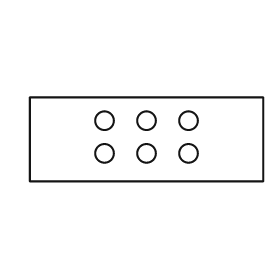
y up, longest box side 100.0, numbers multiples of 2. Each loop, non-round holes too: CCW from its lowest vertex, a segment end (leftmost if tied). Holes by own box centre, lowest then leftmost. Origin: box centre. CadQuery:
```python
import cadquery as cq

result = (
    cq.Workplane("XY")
    .moveTo(-50.0, -18.0)
    .lineTo(50.0, -18.0)
    .lineTo(50.0, 18.0)
    .lineTo(-50.0, 18.0)
    .close()
    .moveTo(-18.0, -6.0)
    .circle(4.0)
    .moveTo(0.0, -6.0)
    .circle(4.0)
    .moveTo(18.0, -6.0)
    .circle(4.0)
    .moveTo(-18.0, 8.0)
    .circle(4.0)
    .moveTo(0.0, 8.0)
    .circle(4.0)
    .moveTo(18.0, 8.0)
    .circle(4.0)
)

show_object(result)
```